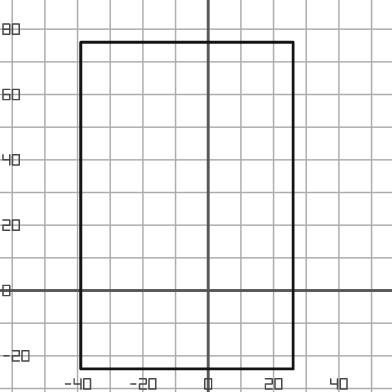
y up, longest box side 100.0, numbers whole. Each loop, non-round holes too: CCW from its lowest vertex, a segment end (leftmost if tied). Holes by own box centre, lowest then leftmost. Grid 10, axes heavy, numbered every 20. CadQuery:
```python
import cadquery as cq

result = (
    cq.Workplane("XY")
    .moveTo(-39.0, -24.0)
    .lineTo(26.0, -24.0)
    .lineTo(26.0, 76.0)
    .lineTo(-39.0, 76.0)
    .close()
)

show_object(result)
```